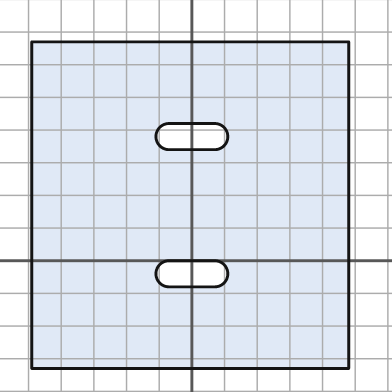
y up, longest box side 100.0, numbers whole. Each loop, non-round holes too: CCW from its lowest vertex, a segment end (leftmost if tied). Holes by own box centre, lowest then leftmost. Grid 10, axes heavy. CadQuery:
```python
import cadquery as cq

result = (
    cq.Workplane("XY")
    .moveTo(-49.0, -33.0)
    .lineTo(48.0, -33.0)
    .lineTo(48.0, 67.0)
    .lineTo(-49.0, 67.0)
    .close()
    .moveTo(-7.0, -8.0)
    .lineTo(7.0, -8.0)
    .threePointArc((11.0, -4.0), (7.0, 0.0))
    .lineTo(-7.0, 0.0)
    .threePointArc((-11.0, -4.0), (-7.0, -8.0))
    .close()
    .moveTo(-7.0, 34.0)
    .lineTo(7.0, 34.0)
    .threePointArc((11.0, 38.0), (7.0, 42.0))
    .lineTo(-7.0, 42.0)
    .threePointArc((-11.0, 38.0), (-7.0, 34.0))
    .close()
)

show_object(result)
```